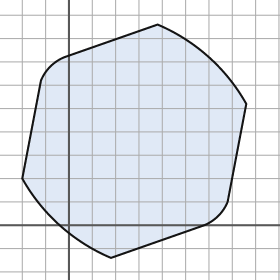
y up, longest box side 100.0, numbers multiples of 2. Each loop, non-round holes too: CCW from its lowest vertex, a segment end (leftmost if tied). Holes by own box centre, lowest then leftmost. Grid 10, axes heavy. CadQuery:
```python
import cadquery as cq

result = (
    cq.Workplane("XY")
    .moveTo(18.0, -14.0)
    .lineTo(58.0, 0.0)
    .threePointArc((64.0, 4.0), (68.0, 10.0))
    .lineTo(76.0, 52.0)
    .threePointArc((60.0, 72.0), (38.0, 86.0))
    .lineTo(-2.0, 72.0)
    .threePointArc((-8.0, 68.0), (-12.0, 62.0))
    .lineTo(-20.0, 20.0)
    .threePointArc((-4.0, 0.0), (18.0, -14.0))
    .close()
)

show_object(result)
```